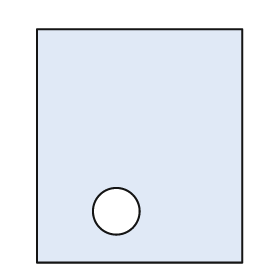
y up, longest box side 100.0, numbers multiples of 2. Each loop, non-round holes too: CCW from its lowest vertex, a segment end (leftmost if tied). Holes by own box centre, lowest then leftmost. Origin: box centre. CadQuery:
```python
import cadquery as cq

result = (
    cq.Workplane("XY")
    .moveTo(-44.0, -50.0)
    .lineTo(44.0, -50.0)
    .lineTo(44.0, 50.0)
    .lineTo(-44.0, 50.0)
    .close()
    .moveTo(-10.0, -28.0)
    .circle(10.0)
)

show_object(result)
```